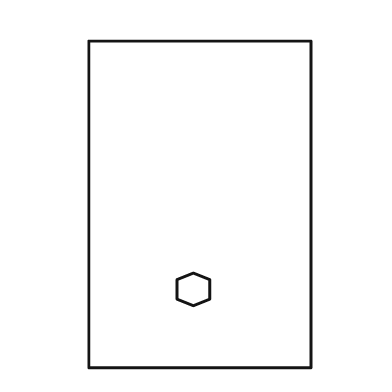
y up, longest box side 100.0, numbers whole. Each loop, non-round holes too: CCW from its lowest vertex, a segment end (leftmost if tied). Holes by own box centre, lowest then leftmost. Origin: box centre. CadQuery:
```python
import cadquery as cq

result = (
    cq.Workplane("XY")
    .moveTo(-34.0, -50.0)
    .lineTo(34.0, -50.0)
    .lineTo(34.0, 50.0)
    .lineTo(-34.0, 50.0)
    .close()
    .moveTo(-2.0, -31.0)
    .lineTo(3.0, -29.0)
    .lineTo(3.0, -23.0)
    .lineTo(-2.0, -21.0)
    .lineTo(-7.0, -23.0)
    .lineTo(-7.0, -29.0)
    .close()
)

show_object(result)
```